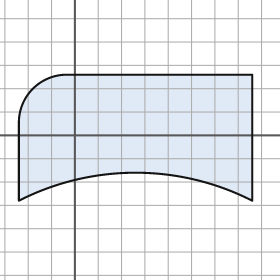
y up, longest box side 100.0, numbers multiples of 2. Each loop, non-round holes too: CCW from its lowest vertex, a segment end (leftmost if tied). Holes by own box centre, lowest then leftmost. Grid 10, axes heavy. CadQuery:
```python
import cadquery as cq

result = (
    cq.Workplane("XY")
    .moveTo(-24.0, -28.0)
    .threePointArc((26.0, -16.0), (76.0, -28.0))
    .lineTo(76.0, 26.0)
    .lineTo(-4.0, 26.0)
    .threePointArc((-18.0, 20.0), (-24.0, 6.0))
    .close()
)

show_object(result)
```